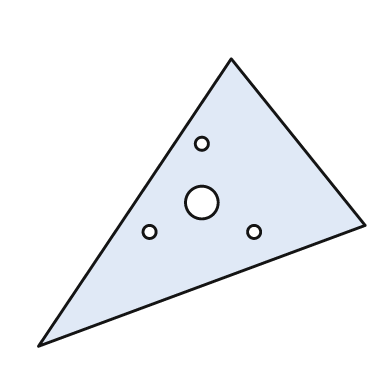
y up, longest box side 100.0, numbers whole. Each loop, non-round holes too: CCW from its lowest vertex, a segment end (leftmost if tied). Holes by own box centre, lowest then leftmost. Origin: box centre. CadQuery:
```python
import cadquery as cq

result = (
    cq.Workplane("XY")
    .moveTo(-50.0, -44.0)
    .lineTo(50.0, -7.0)
    .lineTo(9.0, 44.0)
    .close()
    .moveTo(-16.0, -9.0)
    .circle(2.0)
    .moveTo(16.0, -9.0)
    .circle(2.0)
    .moveTo(0.0, 0.0)
    .circle(5.0)
    .moveTo(0.0, 18.0)
    .circle(2.0)
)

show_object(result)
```